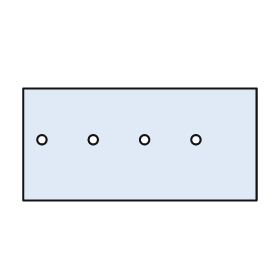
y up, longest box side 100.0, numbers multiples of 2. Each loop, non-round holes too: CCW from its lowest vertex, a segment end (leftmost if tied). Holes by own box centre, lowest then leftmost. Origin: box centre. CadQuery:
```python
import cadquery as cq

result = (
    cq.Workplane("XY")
    .moveTo(-50.0, -24.0)
    .lineTo(50.0, -24.0)
    .lineTo(50.0, 24.0)
    .lineTo(-50.0, 24.0)
    .close()
    .moveTo(-42.0, 2.0)
    .circle(2.0)
    .moveTo(-20.0, 2.0)
    .circle(2.0)
    .moveTo(2.0, 2.0)
    .circle(2.0)
    .moveTo(24.0, 2.0)
    .circle(2.0)
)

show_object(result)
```